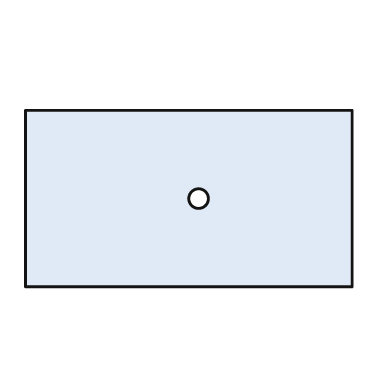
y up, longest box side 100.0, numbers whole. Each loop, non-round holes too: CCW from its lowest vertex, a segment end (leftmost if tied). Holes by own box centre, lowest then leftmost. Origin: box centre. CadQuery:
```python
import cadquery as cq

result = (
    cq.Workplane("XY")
    .moveTo(-50.0, -27.0)
    .lineTo(50.0, -27.0)
    .lineTo(50.0, 27.0)
    .lineTo(-50.0, 27.0)
    .close()
    .moveTo(3.0, 0.0)
    .circle(3.0)
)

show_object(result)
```